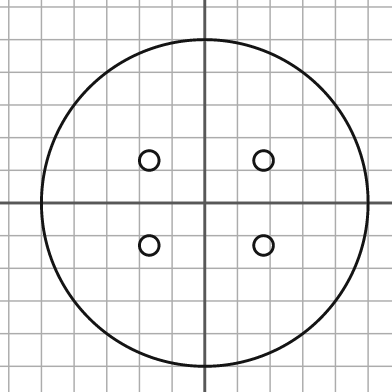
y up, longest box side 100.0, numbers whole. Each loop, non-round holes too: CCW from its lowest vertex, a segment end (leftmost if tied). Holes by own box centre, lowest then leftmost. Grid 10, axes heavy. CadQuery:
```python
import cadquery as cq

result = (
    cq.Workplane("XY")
    .moveTo(0.0, 0.0)
    .circle(50.0)
    .moveTo(-17.0, -13.0)
    .circle(3.0)
    .moveTo(18.0, -13.0)
    .circle(3.0)
    .moveTo(-17.0, 13.0)
    .circle(3.0)
    .moveTo(18.0, 13.0)
    .circle(3.0)
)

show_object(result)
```